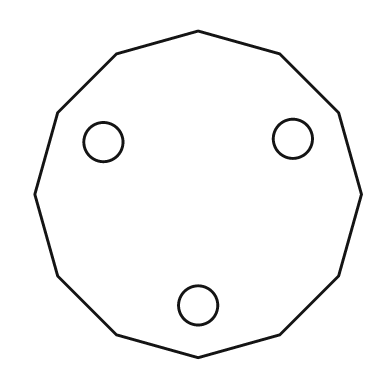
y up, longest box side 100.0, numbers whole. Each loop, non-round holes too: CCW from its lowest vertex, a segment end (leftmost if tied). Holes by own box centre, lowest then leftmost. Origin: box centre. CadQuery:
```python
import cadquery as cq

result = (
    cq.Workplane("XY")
    .moveTo(0.0, -50.0)
    .lineTo(25.0, -43.0)
    .lineTo(43.0, -25.0)
    .lineTo(50.0, 0.0)
    .lineTo(43.0, 25.0)
    .lineTo(25.0, 43.0)
    .lineTo(0.0, 50.0)
    .lineTo(-25.0, 43.0)
    .lineTo(-43.0, 25.0)
    .lineTo(-50.0, 0.0)
    .lineTo(-43.0, -25.0)
    .lineTo(-25.0, -43.0)
    .close()
    .moveTo(0.0, -34.0)
    .circle(6.0)
    .moveTo(-29.0, 16.0)
    .circle(6.0)
    .moveTo(29.0, 17.0)
    .circle(6.0)
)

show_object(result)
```